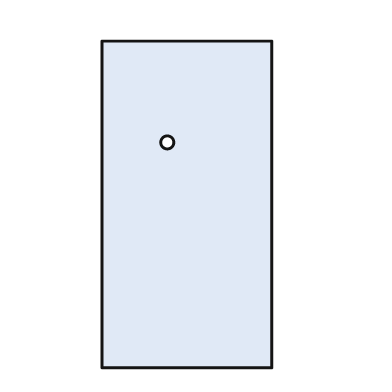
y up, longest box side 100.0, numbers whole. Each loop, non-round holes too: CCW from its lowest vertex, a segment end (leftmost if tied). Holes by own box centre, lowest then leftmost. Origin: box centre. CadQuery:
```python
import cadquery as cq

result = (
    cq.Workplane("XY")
    .moveTo(-26.0, -50.0)
    .lineTo(26.0, -50.0)
    .lineTo(26.0, 50.0)
    .lineTo(-26.0, 50.0)
    .close()
    .moveTo(-6.0, 19.0)
    .circle(2.0)
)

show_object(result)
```